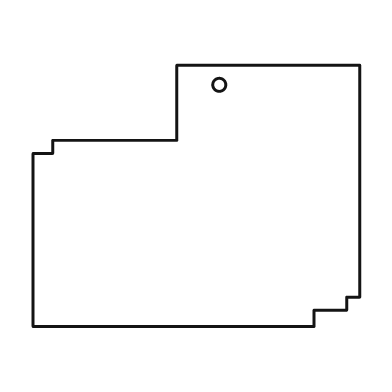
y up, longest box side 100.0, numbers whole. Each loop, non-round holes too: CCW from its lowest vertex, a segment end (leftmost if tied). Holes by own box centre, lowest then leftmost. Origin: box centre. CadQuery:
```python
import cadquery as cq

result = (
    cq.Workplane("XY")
    .moveTo(-50.0, -40.0)
    .lineTo(36.0, -40.0)
    .lineTo(36.0, -35.0)
    .lineTo(46.0, -35.0)
    .lineTo(46.0, -31.0)
    .lineTo(50.0, -31.0)
    .lineTo(50.0, 40.0)
    .lineTo(-6.0, 40.0)
    .lineTo(-6.0, 17.0)
    .lineTo(-44.0, 17.0)
    .lineTo(-44.0, 13.0)
    .lineTo(-50.0, 13.0)
    .close()
    .moveTo(7.0, 34.0)
    .circle(2.0)
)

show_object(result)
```